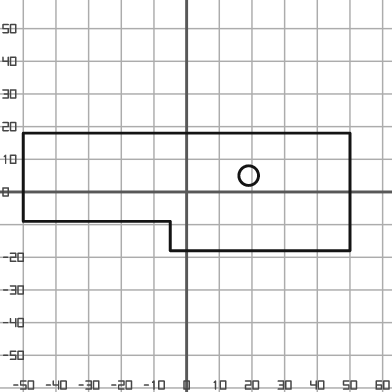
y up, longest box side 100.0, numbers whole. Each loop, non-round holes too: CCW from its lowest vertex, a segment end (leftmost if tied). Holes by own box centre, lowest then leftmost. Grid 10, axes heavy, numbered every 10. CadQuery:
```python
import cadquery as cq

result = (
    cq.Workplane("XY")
    .moveTo(-5.0, -18.0)
    .lineTo(50.0, -18.0)
    .lineTo(50.0, 18.0)
    .lineTo(-50.0, 18.0)
    .lineTo(-50.0, -9.0)
    .lineTo(-5.0, -9.0)
    .close()
    .moveTo(19.0, 5.0)
    .circle(3.0)
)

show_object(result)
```